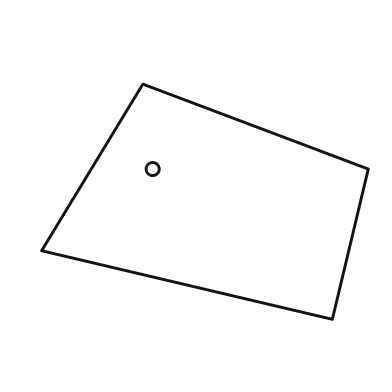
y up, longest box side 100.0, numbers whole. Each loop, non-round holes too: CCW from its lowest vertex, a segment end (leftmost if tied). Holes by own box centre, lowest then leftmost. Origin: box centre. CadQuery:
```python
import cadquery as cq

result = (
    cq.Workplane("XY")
    .moveTo(39.0, -36.0)
    .lineTo(50.0, 10.0)
    .lineTo(-19.0, 36.0)
    .lineTo(-50.0, -15.0)
    .close()
    .moveTo(-16.0, 10.0)
    .circle(2.0)
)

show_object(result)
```